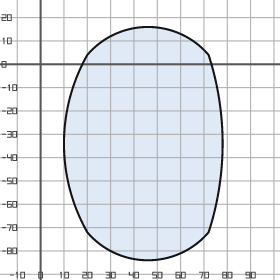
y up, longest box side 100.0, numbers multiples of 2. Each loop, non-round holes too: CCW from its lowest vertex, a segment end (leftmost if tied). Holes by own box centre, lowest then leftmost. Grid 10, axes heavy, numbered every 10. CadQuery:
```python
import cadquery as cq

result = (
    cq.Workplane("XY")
    .moveTo(20.0, -72.0)
    .threePointArc((46.0, -84.0), (72.0, -72.0))
    .threePointArc((78.0, -34.0), (72.0, 4.0))
    .threePointArc((46.0, 16.0), (20.0, 4.0))
    .threePointArc((10.0, -34.0), (20.0, -72.0))
    .close()
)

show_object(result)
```